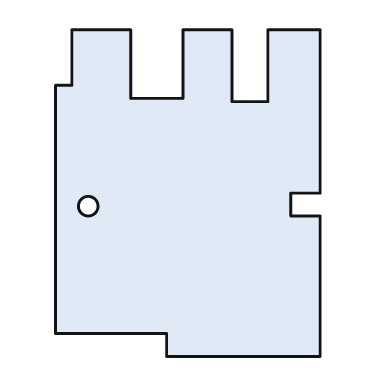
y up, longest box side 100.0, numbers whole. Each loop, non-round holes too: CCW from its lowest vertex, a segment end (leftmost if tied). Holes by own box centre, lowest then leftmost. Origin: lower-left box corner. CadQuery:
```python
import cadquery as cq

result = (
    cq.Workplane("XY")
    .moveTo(34.0, 0.0)
    .lineTo(81.0, 0.0)
    .lineTo(81.0, 43.0)
    .lineTo(72.0, 43.0)
    .lineTo(72.0, 50.0)
    .lineTo(81.0, 50.0)
    .lineTo(81.0, 100.0)
    .lineTo(65.0, 100.0)
    .lineTo(65.0, 78.0)
    .lineTo(54.0, 78.0)
    .lineTo(54.0, 100.0)
    .lineTo(39.0, 100.0)
    .lineTo(39.0, 79.0)
    .lineTo(23.0, 79.0)
    .lineTo(23.0, 100.0)
    .lineTo(5.0, 100.0)
    .lineTo(5.0, 83.0)
    .lineTo(0.0, 83.0)
    .lineTo(0.0, 7.0)
    .lineTo(34.0, 7.0)
    .close()
    .moveTo(10.0, 46.0)
    .circle(3.0)
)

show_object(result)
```